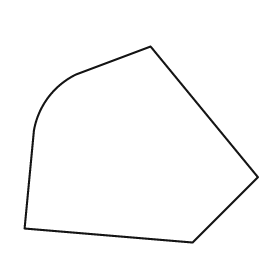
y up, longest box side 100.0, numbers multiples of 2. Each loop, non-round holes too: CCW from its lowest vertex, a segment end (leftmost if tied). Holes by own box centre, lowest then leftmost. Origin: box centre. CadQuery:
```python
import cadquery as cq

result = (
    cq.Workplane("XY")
    .moveTo(22.0, -42.0)
    .lineTo(50.0, -14.0)
    .lineTo(4.0, 42.0)
    .lineTo(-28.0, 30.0)
    .threePointArc((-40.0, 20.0), (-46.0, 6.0))
    .lineTo(-50.0, -36.0)
    .close()
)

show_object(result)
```